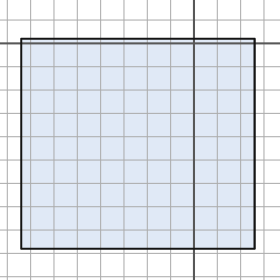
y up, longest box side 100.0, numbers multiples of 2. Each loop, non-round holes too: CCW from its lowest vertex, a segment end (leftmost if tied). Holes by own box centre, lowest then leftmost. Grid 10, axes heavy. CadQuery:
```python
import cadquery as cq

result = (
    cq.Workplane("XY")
    .moveTo(-74.0, -88.0)
    .lineTo(26.0, -88.0)
    .lineTo(26.0, 2.0)
    .lineTo(-74.0, 2.0)
    .close()
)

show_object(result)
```